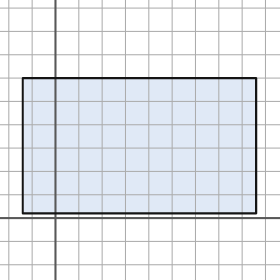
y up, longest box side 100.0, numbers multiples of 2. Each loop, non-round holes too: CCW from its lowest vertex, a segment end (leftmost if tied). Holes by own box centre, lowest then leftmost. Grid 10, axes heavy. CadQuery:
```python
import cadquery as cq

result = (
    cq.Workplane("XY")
    .moveTo(-14.0, 2.0)
    .lineTo(86.0, 2.0)
    .lineTo(86.0, 60.0)
    .lineTo(-14.0, 60.0)
    .close()
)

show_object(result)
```